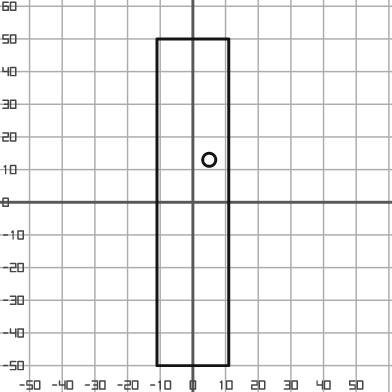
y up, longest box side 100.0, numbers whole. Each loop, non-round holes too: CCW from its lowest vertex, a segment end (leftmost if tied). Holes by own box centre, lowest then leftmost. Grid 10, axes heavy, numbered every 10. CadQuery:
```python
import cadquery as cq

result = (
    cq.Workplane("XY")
    .moveTo(-11.0, -50.0)
    .lineTo(11.0, -50.0)
    .lineTo(11.0, 50.0)
    .lineTo(-11.0, 50.0)
    .close()
    .moveTo(5.0, 13.0)
    .circle(2.0)
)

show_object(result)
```